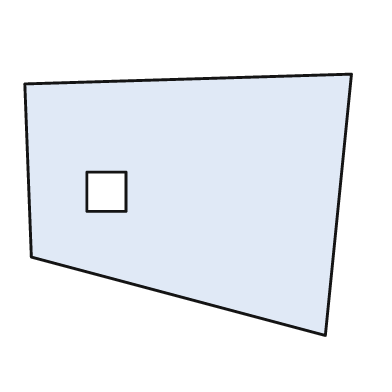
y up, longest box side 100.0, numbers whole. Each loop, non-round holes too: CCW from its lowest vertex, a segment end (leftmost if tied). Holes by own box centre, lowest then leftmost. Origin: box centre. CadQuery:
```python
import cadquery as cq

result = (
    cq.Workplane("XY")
    .moveTo(42.0, -40.0)
    .lineTo(50.0, 40.0)
    .lineTo(-50.0, 37.0)
    .lineTo(-48.0, -16.0)
    .close()
    .moveTo(-31.0, -2.0)
    .lineTo(-19.0, -2.0)
    .lineTo(-19.0, 10.0)
    .lineTo(-31.0, 10.0)
    .close()
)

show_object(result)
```